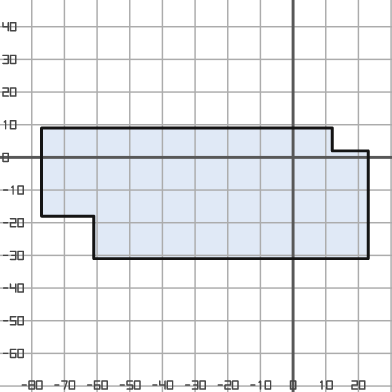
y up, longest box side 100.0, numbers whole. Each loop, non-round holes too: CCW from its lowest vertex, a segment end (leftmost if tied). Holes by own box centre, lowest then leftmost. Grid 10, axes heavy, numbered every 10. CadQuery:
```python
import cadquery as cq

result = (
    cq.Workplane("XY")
    .moveTo(-61.0, -31.0)
    .lineTo(23.0, -31.0)
    .lineTo(23.0, 2.0)
    .lineTo(12.0, 2.0)
    .lineTo(12.0, 9.0)
    .lineTo(-77.0, 9.0)
    .lineTo(-77.0, -18.0)
    .lineTo(-61.0, -18.0)
    .close()
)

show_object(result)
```